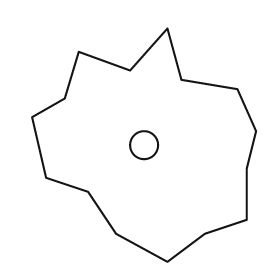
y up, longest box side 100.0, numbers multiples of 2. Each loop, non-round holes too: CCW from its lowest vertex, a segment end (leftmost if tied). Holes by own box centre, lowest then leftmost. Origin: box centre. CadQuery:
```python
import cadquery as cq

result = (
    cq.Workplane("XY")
    .moveTo(10.0, -50.0)
    .lineTo(26.0, -38.0)
    .lineTo(44.0, -32.0)
    .lineTo(44.0, -10.0)
    .lineTo(48.0, 6.0)
    .lineTo(40.0, 24.0)
    .lineTo(16.0, 28.0)
    .lineTo(10.0, 50.0)
    .lineTo(-6.0, 32.0)
    .lineTo(-28.0, 40.0)
    .lineTo(-34.0, 20.0)
    .lineTo(-48.0, 12.0)
    .lineTo(-42.0, -14.0)
    .lineTo(-24.0, -20.0)
    .lineTo(-12.0, -38.0)
    .close()
    .moveTo(0.0, 0.0)
    .circle(6.0)
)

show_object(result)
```